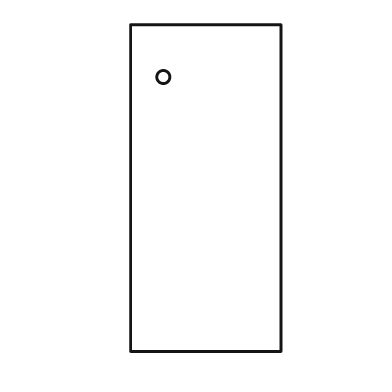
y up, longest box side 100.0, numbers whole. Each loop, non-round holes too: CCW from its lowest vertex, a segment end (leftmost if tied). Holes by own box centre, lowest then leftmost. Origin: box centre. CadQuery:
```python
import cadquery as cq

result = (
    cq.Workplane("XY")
    .moveTo(-23.0, -50.0)
    .lineTo(23.0, -50.0)
    .lineTo(23.0, 50.0)
    .lineTo(-23.0, 50.0)
    .close()
    .moveTo(-13.0, 34.0)
    .circle(2.0)
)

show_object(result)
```